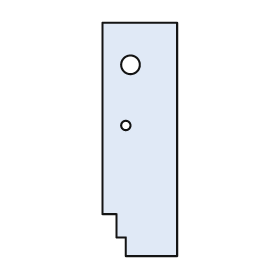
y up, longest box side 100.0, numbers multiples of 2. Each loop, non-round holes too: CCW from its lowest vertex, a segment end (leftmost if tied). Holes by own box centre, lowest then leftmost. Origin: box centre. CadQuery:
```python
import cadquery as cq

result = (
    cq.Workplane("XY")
    .moveTo(-6.0, -50.0)
    .lineTo(16.0, -50.0)
    .lineTo(16.0, 50.0)
    .lineTo(-16.0, 50.0)
    .lineTo(-16.0, -32.0)
    .lineTo(-10.0, -32.0)
    .lineTo(-10.0, -42.0)
    .lineTo(-6.0, -42.0)
    .close()
    .moveTo(-6.0, 6.0)
    .circle(2.0)
    .moveTo(-4.0, 32.0)
    .circle(4.0)
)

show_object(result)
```